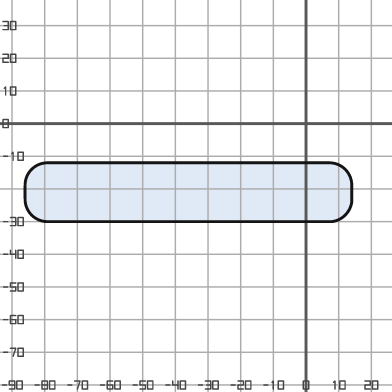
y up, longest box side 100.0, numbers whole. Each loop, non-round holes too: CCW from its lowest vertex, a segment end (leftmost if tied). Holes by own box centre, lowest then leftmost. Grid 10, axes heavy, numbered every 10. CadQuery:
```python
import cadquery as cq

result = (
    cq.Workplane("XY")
    .moveTo(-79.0, -30.0)
    .lineTo(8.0, -30.0)
    .threePointArc((12.0, -28.0), (14.0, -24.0))
    .lineTo(14.0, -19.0)
    .threePointArc((12.0, -14.0), (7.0, -12.0))
    .lineTo(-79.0, -12.0)
    .threePointArc((-84.0, -14.0), (-86.0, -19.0))
    .lineTo(-86.0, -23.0)
    .threePointArc((-84.0, -28.0), (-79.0, -30.0))
    .close()
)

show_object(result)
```